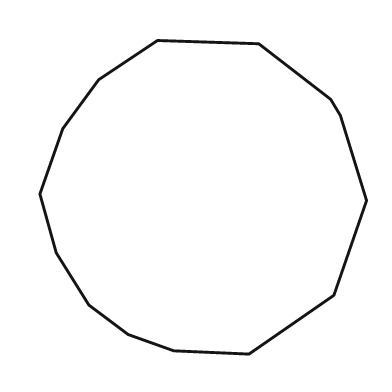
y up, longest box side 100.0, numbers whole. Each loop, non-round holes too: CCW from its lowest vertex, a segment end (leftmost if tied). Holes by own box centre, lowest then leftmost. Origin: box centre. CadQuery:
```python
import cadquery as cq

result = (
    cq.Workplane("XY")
    .moveTo(14.0, -48.0)
    .lineTo(40.0, -30.0)
    .lineTo(50.0, -1.0)
    .lineTo(42.0, 25.0)
    .lineTo(39.0, 30.0)
    .lineTo(17.0, 47.0)
    .lineTo(-14.0, 48.0)
    .lineTo(-32.0, 36.0)
    .lineTo(-43.0, 21.0)
    .lineTo(-50.0, 1.0)
    .lineTo(-45.0, -17.0)
    .lineTo(-35.0, -33.0)
    .lineTo(-23.0, -42.0)
    .lineTo(-9.0, -47.0)
    .close()
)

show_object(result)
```